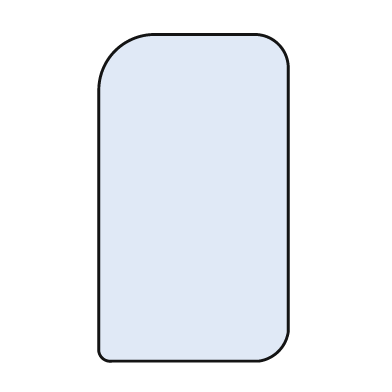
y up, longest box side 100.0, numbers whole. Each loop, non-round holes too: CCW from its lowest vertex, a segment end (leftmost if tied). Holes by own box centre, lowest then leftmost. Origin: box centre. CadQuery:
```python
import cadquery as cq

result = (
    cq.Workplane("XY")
    .moveTo(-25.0, -50.0)
    .lineTo(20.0, -50.0)
    .threePointArc((26.0, -47.0), (29.0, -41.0))
    .lineTo(29.0, 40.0)
    .threePointArc((26.0, 47.0), (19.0, 50.0))
    .lineTo(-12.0, 50.0)
    .threePointArc((-24.0, 45.0), (-29.0, 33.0))
    .lineTo(-29.0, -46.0)
    .threePointArc((-28.0, -49.0), (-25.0, -50.0))
    .close()
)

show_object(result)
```